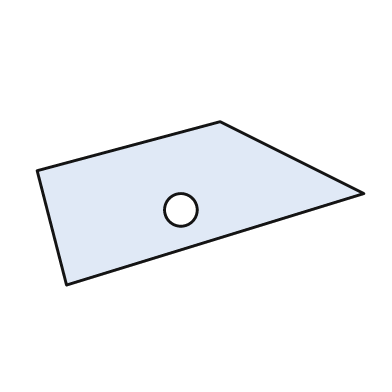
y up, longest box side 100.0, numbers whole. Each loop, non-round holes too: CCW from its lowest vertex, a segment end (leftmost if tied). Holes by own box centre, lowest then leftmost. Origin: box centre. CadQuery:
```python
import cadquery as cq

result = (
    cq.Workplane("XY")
    .moveTo(-41.0, -25.0)
    .lineTo(50.0, 3.0)
    .lineTo(6.0, 25.0)
    .lineTo(-50.0, 10.0)
    .close()
    .moveTo(-6.0, -2.0)
    .circle(5.0)
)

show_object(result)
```